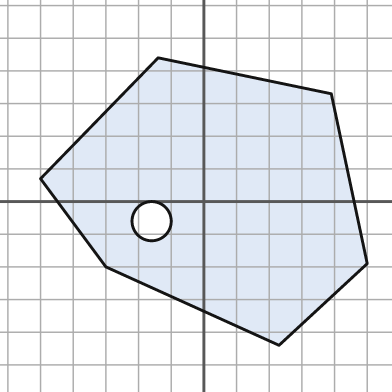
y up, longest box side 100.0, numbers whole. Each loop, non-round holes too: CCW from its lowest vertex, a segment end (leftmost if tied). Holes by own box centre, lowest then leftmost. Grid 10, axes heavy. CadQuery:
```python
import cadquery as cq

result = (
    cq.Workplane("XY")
    .moveTo(23.0, -44.0)
    .lineTo(50.0, -19.0)
    .lineTo(39.0, 33.0)
    .lineTo(-14.0, 44.0)
    .lineTo(-50.0, 7.0)
    .lineTo(-30.0, -20.0)
    .close()
    .moveTo(-16.0, -6.0)
    .circle(6.0)
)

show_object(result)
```